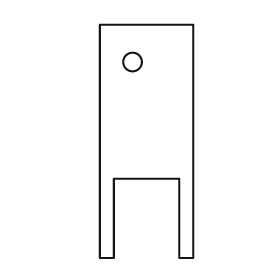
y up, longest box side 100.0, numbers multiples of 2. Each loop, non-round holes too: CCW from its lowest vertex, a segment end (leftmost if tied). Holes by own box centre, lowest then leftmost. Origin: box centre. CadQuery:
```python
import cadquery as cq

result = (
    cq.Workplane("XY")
    .moveTo(-20.0, -50.0)
    .lineTo(-14.0, -50.0)
    .lineTo(-14.0, -16.0)
    .lineTo(14.0, -16.0)
    .lineTo(14.0, -50.0)
    .lineTo(20.0, -50.0)
    .lineTo(20.0, 50.0)
    .lineTo(-20.0, 50.0)
    .close()
    .moveTo(-6.0, 34.0)
    .circle(4.0)
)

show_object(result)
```